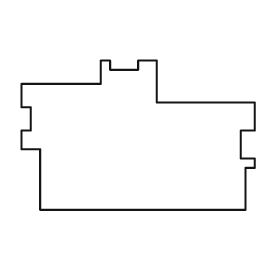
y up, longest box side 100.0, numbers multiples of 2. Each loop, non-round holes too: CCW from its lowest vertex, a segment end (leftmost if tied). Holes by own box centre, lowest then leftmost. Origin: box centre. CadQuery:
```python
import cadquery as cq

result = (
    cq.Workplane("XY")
    .moveTo(-42.0, -32.0)
    .lineTo(46.0, -32.0)
    .lineTo(46.0, -14.0)
    .lineTo(50.0, -14.0)
    .lineTo(50.0, -10.0)
    .lineTo(44.0, -10.0)
    .lineTo(44.0, 2.0)
    .lineTo(50.0, 2.0)
    .lineTo(50.0, 14.0)
    .lineTo(8.0, 14.0)
    .lineTo(8.0, 32.0)
    .lineTo(0.0, 32.0)
    .lineTo(0.0, 28.0)
    .lineTo(-12.0, 28.0)
    .lineTo(-12.0, 32.0)
    .lineTo(-16.0, 32.0)
    .lineTo(-16.0, 22.0)
    .lineTo(-50.0, 22.0)
    .lineTo(-50.0, 12.0)
    .lineTo(-46.0, 12.0)
    .lineTo(-46.0, 2.0)
    .lineTo(-50.0, 2.0)
    .lineTo(-50.0, -6.0)
    .lineTo(-42.0, -6.0)
    .close()
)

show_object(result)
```